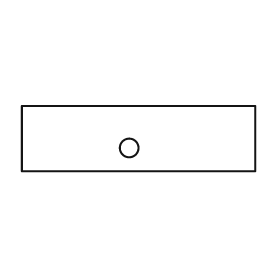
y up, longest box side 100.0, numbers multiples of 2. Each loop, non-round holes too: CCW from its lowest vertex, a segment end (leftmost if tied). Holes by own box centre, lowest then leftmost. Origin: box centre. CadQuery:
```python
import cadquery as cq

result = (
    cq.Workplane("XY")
    .moveTo(-50.0, -14.0)
    .lineTo(50.0, -14.0)
    .lineTo(50.0, 14.0)
    .lineTo(-50.0, 14.0)
    .close()
    .moveTo(-4.0, -4.0)
    .circle(4.0)
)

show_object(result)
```